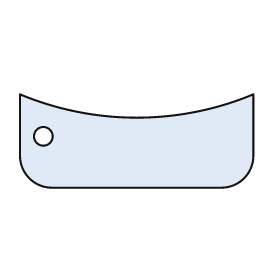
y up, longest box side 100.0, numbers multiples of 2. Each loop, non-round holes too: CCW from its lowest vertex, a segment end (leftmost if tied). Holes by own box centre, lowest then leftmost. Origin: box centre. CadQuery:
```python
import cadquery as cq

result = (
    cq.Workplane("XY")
    .moveTo(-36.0, -20.0)
    .lineTo(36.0, -20.0)
    .threePointArc((46.0, -16.0), (50.0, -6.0))
    .lineTo(50.0, 20.0)
    .threePointArc((0.0, 10.0), (-50.0, 20.0))
    .lineTo(-50.0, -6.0)
    .threePointArc((-46.0, -16.0), (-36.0, -20.0))
    .close()
    .moveTo(-40.0, 2.0)
    .circle(4.0)
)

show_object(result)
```